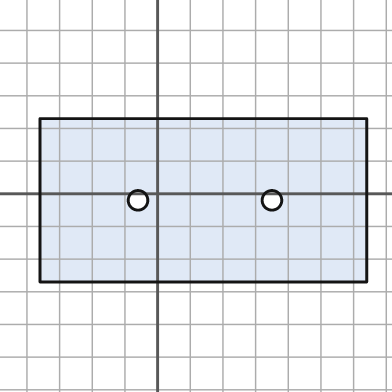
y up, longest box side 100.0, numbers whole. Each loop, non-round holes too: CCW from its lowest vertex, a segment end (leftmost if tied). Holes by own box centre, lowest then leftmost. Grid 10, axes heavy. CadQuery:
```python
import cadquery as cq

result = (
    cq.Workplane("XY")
    .moveTo(-36.0, -27.0)
    .lineTo(64.0, -27.0)
    .lineTo(64.0, 23.0)
    .lineTo(-36.0, 23.0)
    .close()
    .moveTo(-6.0, -2.0)
    .circle(3.0)
    .moveTo(35.0, -2.0)
    .circle(3.0)
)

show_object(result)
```